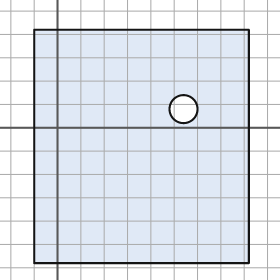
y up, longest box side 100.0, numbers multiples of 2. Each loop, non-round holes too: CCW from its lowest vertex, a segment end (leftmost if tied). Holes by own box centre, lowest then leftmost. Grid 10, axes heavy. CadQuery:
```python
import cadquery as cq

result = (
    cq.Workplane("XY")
    .moveTo(-10.0, -58.0)
    .lineTo(82.0, -58.0)
    .lineTo(82.0, 42.0)
    .lineTo(-10.0, 42.0)
    .close()
    .moveTo(54.0, 8.0)
    .circle(6.0)
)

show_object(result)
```